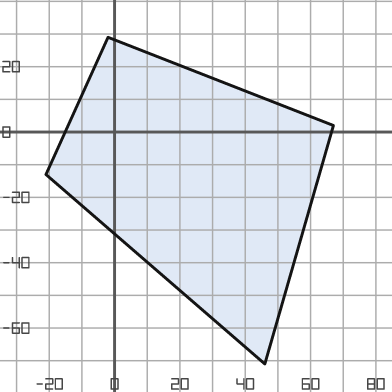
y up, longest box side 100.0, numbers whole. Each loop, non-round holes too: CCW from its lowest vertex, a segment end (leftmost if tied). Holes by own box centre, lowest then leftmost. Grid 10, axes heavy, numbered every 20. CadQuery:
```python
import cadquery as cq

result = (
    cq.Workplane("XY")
    .moveTo(46.0, -71.0)
    .lineTo(67.0, 2.0)
    .lineTo(-2.0, 29.0)
    .lineTo(-21.0, -13.0)
    .close()
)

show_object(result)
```